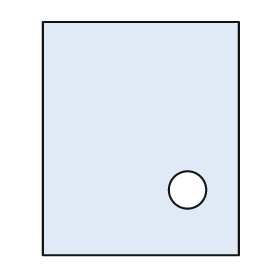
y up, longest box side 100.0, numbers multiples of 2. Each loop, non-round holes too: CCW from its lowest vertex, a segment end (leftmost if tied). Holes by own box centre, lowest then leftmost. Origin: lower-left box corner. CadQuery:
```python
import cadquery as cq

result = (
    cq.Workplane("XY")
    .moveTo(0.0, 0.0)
    .lineTo(84.0, 0.0)
    .lineTo(84.0, 100.0)
    .lineTo(0.0, 100.0)
    .close()
    .moveTo(62.0, 28.0)
    .circle(8.0)
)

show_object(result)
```